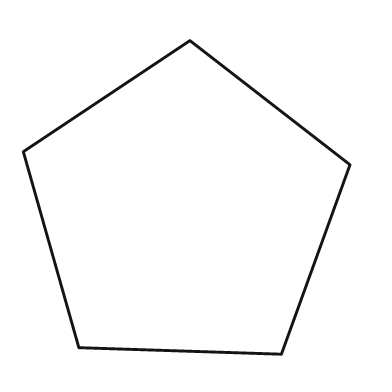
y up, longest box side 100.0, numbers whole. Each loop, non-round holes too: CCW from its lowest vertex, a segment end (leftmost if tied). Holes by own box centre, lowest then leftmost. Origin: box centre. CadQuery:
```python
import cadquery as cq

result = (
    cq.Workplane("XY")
    .moveTo(29.0, -48.0)
    .lineTo(50.0, 10.0)
    .lineTo(1.0, 48.0)
    .lineTo(-50.0, 14.0)
    .lineTo(-33.0, -46.0)
    .close()
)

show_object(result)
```